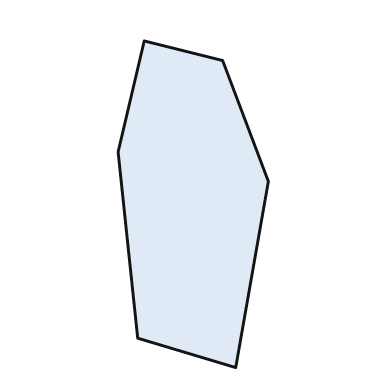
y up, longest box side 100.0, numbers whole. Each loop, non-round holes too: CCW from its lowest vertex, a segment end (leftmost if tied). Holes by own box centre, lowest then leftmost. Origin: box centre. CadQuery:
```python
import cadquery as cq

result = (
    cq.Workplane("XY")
    .moveTo(13.0, -50.0)
    .lineTo(23.0, 7.0)
    .lineTo(9.0, 44.0)
    .lineTo(-15.0, 50.0)
    .lineTo(-23.0, 16.0)
    .lineTo(-17.0, -41.0)
    .close()
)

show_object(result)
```